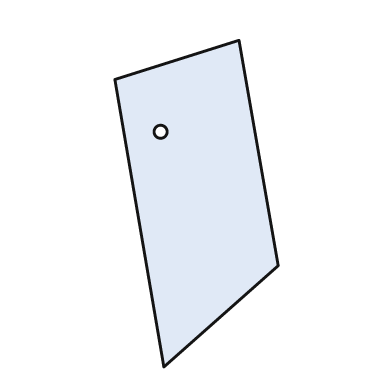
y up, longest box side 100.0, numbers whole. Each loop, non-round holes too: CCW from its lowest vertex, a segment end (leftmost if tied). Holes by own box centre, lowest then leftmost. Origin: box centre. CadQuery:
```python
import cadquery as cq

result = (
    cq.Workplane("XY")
    .moveTo(-10.0, -50.0)
    .lineTo(25.0, -19.0)
    .lineTo(13.0, 50.0)
    .lineTo(-25.0, 38.0)
    .close()
    .moveTo(-11.0, 22.0)
    .circle(2.0)
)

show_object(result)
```